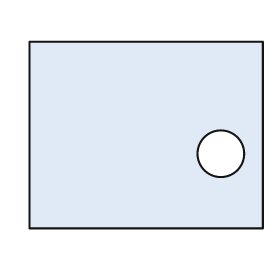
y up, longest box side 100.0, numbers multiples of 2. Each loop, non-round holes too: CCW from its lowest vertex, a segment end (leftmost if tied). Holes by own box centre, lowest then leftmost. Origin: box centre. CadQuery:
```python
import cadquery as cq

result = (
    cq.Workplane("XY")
    .moveTo(-50.0, -40.0)
    .lineTo(50.0, -40.0)
    .lineTo(50.0, 40.0)
    .lineTo(-50.0, 40.0)
    .close()
    .moveTo(32.0, -8.0)
    .circle(10.0)
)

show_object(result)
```